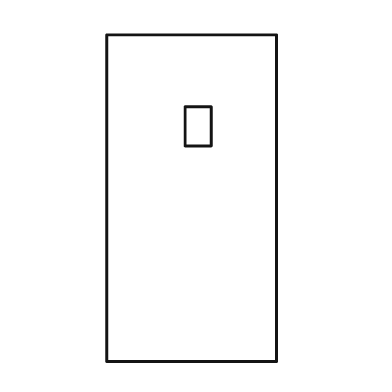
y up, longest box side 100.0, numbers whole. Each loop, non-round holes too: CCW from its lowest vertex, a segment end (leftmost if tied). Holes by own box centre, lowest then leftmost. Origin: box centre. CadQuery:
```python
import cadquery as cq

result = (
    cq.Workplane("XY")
    .moveTo(-26.0, -50.0)
    .lineTo(26.0, -50.0)
    .lineTo(26.0, 50.0)
    .lineTo(-26.0, 50.0)
    .close()
    .moveTo(-2.0, 16.0)
    .lineTo(6.0, 16.0)
    .lineTo(6.0, 28.0)
    .lineTo(-2.0, 28.0)
    .close()
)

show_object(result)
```